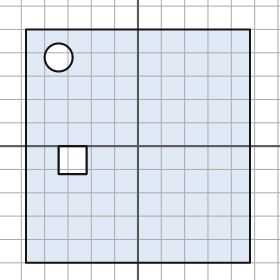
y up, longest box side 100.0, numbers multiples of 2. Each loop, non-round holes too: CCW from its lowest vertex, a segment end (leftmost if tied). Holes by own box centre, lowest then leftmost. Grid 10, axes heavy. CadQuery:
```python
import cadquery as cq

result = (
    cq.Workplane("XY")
    .moveTo(-48.0, -50.0)
    .lineTo(48.0, -50.0)
    .lineTo(48.0, 50.0)
    .lineTo(-48.0, 50.0)
    .close()
    .moveTo(-34.0, -12.0)
    .lineTo(-22.0, -12.0)
    .lineTo(-22.0, 0.0)
    .lineTo(-34.0, 0.0)
    .close()
    .moveTo(-34.0, 38.0)
    .circle(6.0)
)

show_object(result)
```